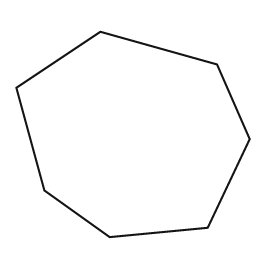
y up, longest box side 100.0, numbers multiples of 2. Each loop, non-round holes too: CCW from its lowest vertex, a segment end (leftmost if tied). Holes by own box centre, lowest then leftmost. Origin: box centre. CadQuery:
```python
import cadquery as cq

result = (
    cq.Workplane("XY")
    .moveTo(-10.0, -44.0)
    .lineTo(32.0, -40.0)
    .lineTo(50.0, -2.0)
    .lineTo(36.0, 30.0)
    .lineTo(-14.0, 44.0)
    .lineTo(-50.0, 20.0)
    .lineTo(-38.0, -24.0)
    .close()
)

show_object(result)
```